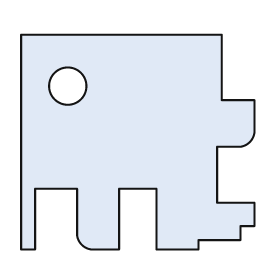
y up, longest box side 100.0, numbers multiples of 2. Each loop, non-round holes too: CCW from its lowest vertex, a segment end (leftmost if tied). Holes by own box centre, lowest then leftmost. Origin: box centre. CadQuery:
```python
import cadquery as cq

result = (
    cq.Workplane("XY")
    .moveTo(-50.0, -46.0)
    .lineTo(-44.0, -46.0)
    .lineTo(-44.0, -20.0)
    .lineTo(-26.0, -20.0)
    .lineTo(-26.0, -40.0)
    .threePointArc((-24.0, -44.0), (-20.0, -46.0))
    .lineTo(-8.0, -46.0)
    .lineTo(-8.0, -20.0)
    .lineTo(8.0, -20.0)
    .lineTo(8.0, -46.0)
    .lineTo(26.0, -46.0)
    .lineTo(26.0, -42.0)
    .lineTo(44.0, -42.0)
    .lineTo(44.0, -36.0)
    .lineTo(50.0, -36.0)
    .lineTo(50.0, -26.0)
    .lineTo(34.0, -26.0)
    .lineTo(34.0, -2.0)
    .lineTo(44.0, -2.0)
    .threePointArc((48.0, 0.0), (50.0, 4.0))
    .lineTo(50.0, 18.0)
    .lineTo(36.0, 18.0)
    .lineTo(36.0, 46.0)
    .lineTo(-50.0, 46.0)
    .close()
    .moveTo(-30.0, 24.0)
    .circle(8.0)
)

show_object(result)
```